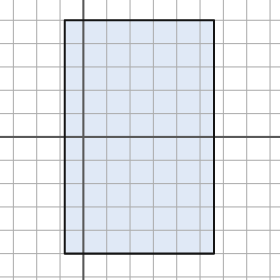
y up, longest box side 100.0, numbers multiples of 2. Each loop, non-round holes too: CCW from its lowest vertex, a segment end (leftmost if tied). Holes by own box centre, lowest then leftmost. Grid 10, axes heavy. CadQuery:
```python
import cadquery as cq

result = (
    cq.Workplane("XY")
    .moveTo(-8.0, -50.0)
    .lineTo(56.0, -50.0)
    .lineTo(56.0, 50.0)
    .lineTo(-8.0, 50.0)
    .close()
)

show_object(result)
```